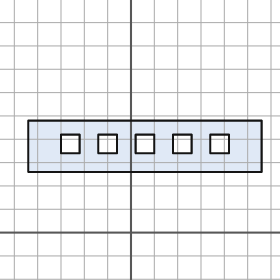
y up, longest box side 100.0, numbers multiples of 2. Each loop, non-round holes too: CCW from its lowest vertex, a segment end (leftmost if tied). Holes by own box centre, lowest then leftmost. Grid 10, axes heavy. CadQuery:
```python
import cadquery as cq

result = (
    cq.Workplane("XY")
    .moveTo(-44.0, 26.0)
    .lineTo(56.0, 26.0)
    .lineTo(56.0, 48.0)
    .lineTo(-44.0, 48.0)
    .close()
    .moveTo(-30.0, 34.0)
    .lineTo(-22.0, 34.0)
    .lineTo(-22.0, 42.0)
    .lineTo(-30.0, 42.0)
    .close()
    .moveTo(-14.0, 34.0)
    .lineTo(-6.0, 34.0)
    .lineTo(-6.0, 42.0)
    .lineTo(-14.0, 42.0)
    .close()
    .moveTo(2.0, 34.0)
    .lineTo(10.0, 34.0)
    .lineTo(10.0, 42.0)
    .lineTo(2.0, 42.0)
    .close()
    .moveTo(18.0, 34.0)
    .lineTo(26.0, 34.0)
    .lineTo(26.0, 42.0)
    .lineTo(18.0, 42.0)
    .close()
    .moveTo(34.0, 34.0)
    .lineTo(42.0, 34.0)
    .lineTo(42.0, 42.0)
    .lineTo(34.0, 42.0)
    .close()
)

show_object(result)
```